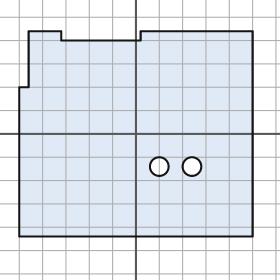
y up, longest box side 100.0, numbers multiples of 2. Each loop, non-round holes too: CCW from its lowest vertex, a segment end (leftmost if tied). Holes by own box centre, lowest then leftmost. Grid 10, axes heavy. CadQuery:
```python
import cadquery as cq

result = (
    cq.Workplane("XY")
    .moveTo(-50.0, -44.0)
    .lineTo(50.0, -44.0)
    .lineTo(50.0, 44.0)
    .lineTo(2.0, 44.0)
    .lineTo(2.0, 40.0)
    .lineTo(-32.0, 40.0)
    .lineTo(-32.0, 44.0)
    .lineTo(-46.0, 44.0)
    .lineTo(-46.0, 20.0)
    .lineTo(-50.0, 20.0)
    .close()
    .moveTo(10.0, -14.0)
    .circle(4.0)
    .moveTo(24.0, -14.0)
    .circle(4.0)
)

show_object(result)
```